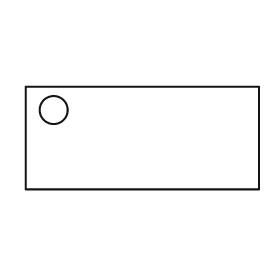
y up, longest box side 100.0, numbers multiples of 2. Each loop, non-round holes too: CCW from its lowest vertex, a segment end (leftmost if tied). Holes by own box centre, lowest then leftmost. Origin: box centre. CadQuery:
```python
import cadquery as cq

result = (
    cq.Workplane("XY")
    .moveTo(-50.0, -22.0)
    .lineTo(50.0, -22.0)
    .lineTo(50.0, 22.0)
    .lineTo(-50.0, 22.0)
    .close()
    .moveTo(-38.0, 12.0)
    .circle(6.0)
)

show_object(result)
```